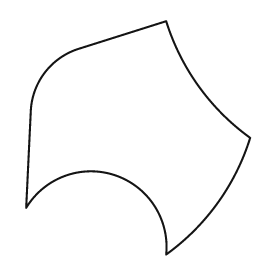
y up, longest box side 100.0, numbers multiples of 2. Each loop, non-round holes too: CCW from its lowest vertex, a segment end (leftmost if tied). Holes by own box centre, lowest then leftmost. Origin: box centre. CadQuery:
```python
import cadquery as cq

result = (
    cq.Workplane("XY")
    .moveTo(12.0, -50.0)
    .threePointArc((34.0, -28.0), (48.0, 0.0))
    .threePointArc((26.0, 22.0), (12.0, 50.0))
    .lineTo(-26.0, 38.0)
    .threePointArc((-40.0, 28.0), (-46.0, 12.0))
    .lineTo(-48.0, -30.0)
    .threePointArc((-10.0, -16.0), (12.0, -50.0))
    .close()
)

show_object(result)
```